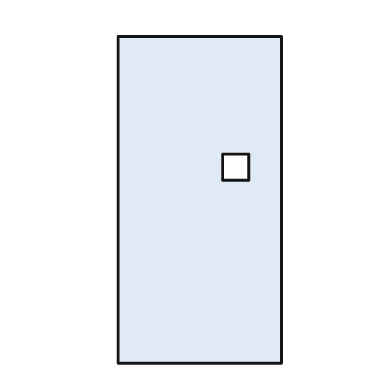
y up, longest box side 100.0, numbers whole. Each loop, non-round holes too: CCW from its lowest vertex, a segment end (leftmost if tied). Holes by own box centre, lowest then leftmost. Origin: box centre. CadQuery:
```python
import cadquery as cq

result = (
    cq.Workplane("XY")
    .moveTo(-25.0, -50.0)
    .lineTo(25.0, -50.0)
    .lineTo(25.0, 50.0)
    .lineTo(-25.0, 50.0)
    .close()
    .moveTo(7.0, 6.0)
    .lineTo(15.0, 6.0)
    .lineTo(15.0, 14.0)
    .lineTo(7.0, 14.0)
    .close()
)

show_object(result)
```